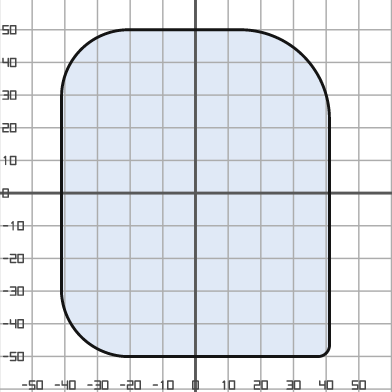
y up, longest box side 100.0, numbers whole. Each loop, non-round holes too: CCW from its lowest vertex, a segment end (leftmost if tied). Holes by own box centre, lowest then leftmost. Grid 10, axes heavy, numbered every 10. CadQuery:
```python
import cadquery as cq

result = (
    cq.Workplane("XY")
    .moveTo(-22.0, -50.0)
    .lineTo(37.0, -50.0)
    .threePointArc((40.0, -49.0), (41.0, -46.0))
    .lineTo(41.0, 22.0)
    .threePointArc((33.0, 42.0), (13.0, 50.0))
    .lineTo(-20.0, 50.0)
    .threePointArc((-35.0, 44.0), (-41.0, 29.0))
    .lineTo(-41.0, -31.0)
    .threePointArc((-35.0, -44.0), (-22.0, -50.0))
    .close()
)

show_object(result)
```